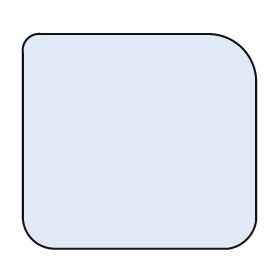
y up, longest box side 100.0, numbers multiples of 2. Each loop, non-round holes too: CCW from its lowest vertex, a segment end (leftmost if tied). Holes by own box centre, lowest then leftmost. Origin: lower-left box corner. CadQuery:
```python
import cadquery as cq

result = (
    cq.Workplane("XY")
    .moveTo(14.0, 0.0)
    .lineTo(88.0, 0.0)
    .threePointArc((96.0, 4.0), (100.0, 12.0))
    .lineTo(100.0, 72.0)
    .threePointArc((94.0, 86.0), (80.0, 92.0))
    .lineTo(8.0, 92.0)
    .threePointArc((2.0, 90.0), (0.0, 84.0))
    .lineTo(0.0, 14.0)
    .threePointArc((4.0, 4.0), (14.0, 0.0))
    .close()
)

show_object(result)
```